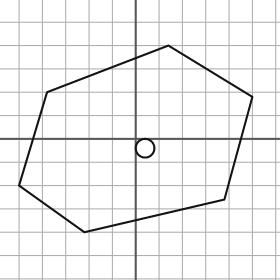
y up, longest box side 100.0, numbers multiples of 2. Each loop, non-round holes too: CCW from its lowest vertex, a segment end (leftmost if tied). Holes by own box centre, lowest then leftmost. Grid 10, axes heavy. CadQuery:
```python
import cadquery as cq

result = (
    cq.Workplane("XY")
    .moveTo(-22.0, -40.0)
    .lineTo(38.0, -26.0)
    .lineTo(50.0, 18.0)
    .lineTo(14.0, 40.0)
    .lineTo(-38.0, 20.0)
    .lineTo(-50.0, -20.0)
    .close()
    .moveTo(4.0, -4.0)
    .circle(4.0)
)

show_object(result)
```